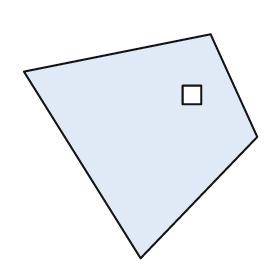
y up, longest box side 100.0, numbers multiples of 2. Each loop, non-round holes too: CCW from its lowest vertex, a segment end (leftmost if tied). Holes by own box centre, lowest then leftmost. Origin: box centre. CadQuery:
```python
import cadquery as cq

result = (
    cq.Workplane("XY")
    .moveTo(0.0, -48.0)
    .lineTo(50.0, 4.0)
    .lineTo(30.0, 48.0)
    .lineTo(-50.0, 32.0)
    .close()
    .moveTo(18.0, 18.0)
    .lineTo(26.0, 18.0)
    .lineTo(26.0, 26.0)
    .lineTo(18.0, 26.0)
    .close()
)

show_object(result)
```